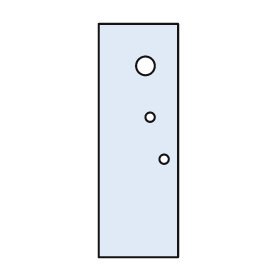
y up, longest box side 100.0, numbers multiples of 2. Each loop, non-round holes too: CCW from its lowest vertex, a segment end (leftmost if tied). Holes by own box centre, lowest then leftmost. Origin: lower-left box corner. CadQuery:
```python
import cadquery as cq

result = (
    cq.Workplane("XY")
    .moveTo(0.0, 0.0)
    .lineTo(34.0, 0.0)
    .lineTo(34.0, 100.0)
    .lineTo(0.0, 100.0)
    .close()
    .moveTo(28.0, 42.0)
    .circle(2.0)
    .moveTo(22.0, 60.0)
    .circle(2.0)
    .moveTo(20.0, 82.0)
    .circle(4.0)
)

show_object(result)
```